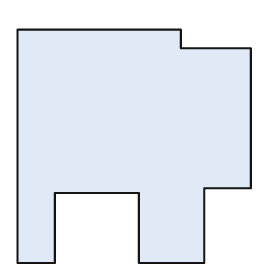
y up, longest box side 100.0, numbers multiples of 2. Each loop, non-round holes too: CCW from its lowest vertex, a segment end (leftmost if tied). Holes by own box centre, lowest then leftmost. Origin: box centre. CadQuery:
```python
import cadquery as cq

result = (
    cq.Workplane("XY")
    .moveTo(-50.0, -50.0)
    .lineTo(-34.0, -50.0)
    .lineTo(-34.0, -20.0)
    .lineTo(2.0, -20.0)
    .lineTo(2.0, -50.0)
    .lineTo(30.0, -50.0)
    .lineTo(30.0, -18.0)
    .lineTo(50.0, -18.0)
    .lineTo(50.0, 42.0)
    .lineTo(20.0, 42.0)
    .lineTo(20.0, 50.0)
    .lineTo(-50.0, 50.0)
    .close()
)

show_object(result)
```